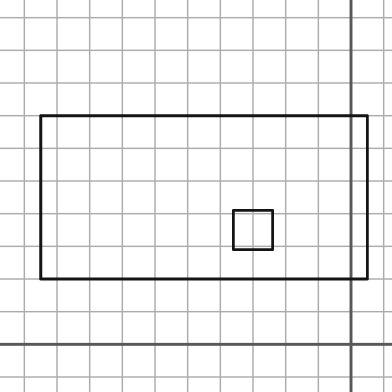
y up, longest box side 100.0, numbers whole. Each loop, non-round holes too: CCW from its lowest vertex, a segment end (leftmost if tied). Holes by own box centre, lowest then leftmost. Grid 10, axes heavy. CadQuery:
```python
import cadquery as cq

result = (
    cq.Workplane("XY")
    .moveTo(-95.0, 20.0)
    .lineTo(5.0, 20.0)
    .lineTo(5.0, 70.0)
    .lineTo(-95.0, 70.0)
    .close()
    .moveTo(-36.0, 29.0)
    .lineTo(-24.0, 29.0)
    .lineTo(-24.0, 41.0)
    .lineTo(-36.0, 41.0)
    .close()
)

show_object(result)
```